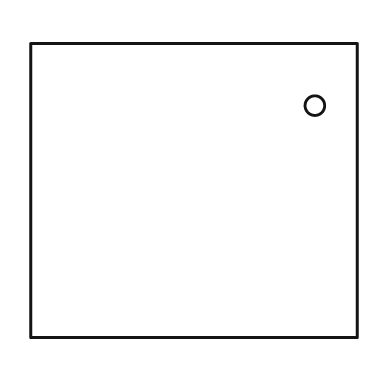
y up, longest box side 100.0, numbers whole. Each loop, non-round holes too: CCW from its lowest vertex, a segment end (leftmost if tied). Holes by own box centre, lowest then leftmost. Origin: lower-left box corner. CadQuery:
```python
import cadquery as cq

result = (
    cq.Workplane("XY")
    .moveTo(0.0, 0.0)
    .lineTo(100.0, 0.0)
    .lineTo(100.0, 90.0)
    .lineTo(0.0, 90.0)
    .close()
    .moveTo(87.0, 71.0)
    .circle(3.0)
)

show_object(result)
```